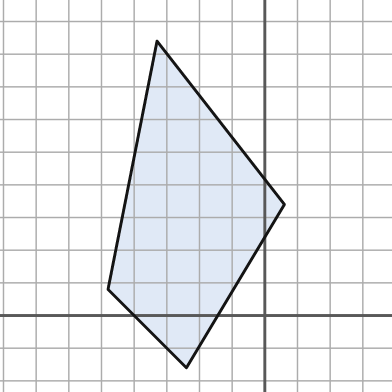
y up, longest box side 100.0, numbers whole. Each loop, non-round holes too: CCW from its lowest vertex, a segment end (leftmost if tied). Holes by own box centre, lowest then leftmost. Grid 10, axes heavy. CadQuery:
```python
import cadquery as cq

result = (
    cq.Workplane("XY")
    .moveTo(-24.0, -16.0)
    .lineTo(6.0, 34.0)
    .lineTo(-33.0, 84.0)
    .lineTo(-48.0, 8.0)
    .close()
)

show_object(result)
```